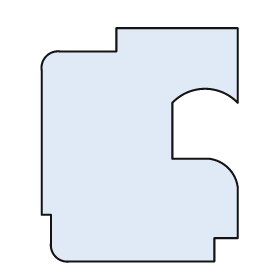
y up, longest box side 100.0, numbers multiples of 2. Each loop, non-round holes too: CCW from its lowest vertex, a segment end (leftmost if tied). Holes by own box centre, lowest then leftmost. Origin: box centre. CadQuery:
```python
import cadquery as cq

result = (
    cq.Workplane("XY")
    .moveTo(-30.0, -50.0)
    .lineTo(32.0, -50.0)
    .lineTo(32.0, -40.0)
    .lineTo(42.0, -40.0)
    .lineTo(42.0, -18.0)
    .threePointArc((38.0, -10.0), (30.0, -6.0))
    .lineTo(14.0, -6.0)
    .lineTo(14.0, 18.0)
    .threePointArc((28.0, 24.0), (42.0, 18.0))
    .lineTo(42.0, 50.0)
    .lineTo(-10.0, 50.0)
    .lineTo(-10.0, 40.0)
    .lineTo(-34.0, 40.0)
    .threePointArc((-40.0, 38.0), (-42.0, 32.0))
    .lineTo(-42.0, -30.0)
    .lineTo(-38.0, -30.0)
    .lineTo(-38.0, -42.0)
    .threePointArc((-36.0, -48.0), (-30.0, -50.0))
    .close()
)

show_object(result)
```